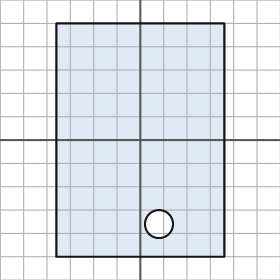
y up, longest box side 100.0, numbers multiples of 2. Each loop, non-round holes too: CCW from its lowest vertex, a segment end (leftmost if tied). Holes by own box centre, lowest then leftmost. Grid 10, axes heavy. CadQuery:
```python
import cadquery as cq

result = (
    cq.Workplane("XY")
    .moveTo(-36.0, -50.0)
    .lineTo(36.0, -50.0)
    .lineTo(36.0, 50.0)
    .lineTo(-36.0, 50.0)
    .close()
    .moveTo(8.0, -36.0)
    .circle(6.0)
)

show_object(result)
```